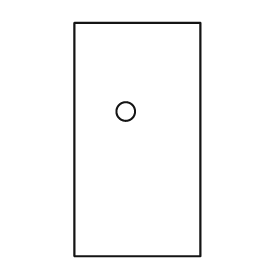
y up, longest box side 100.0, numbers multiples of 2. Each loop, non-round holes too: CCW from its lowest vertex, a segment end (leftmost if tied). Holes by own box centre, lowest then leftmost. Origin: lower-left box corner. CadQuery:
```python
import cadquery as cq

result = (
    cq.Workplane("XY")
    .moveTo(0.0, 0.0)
    .lineTo(54.0, 0.0)
    .lineTo(54.0, 100.0)
    .lineTo(0.0, 100.0)
    .close()
    .moveTo(22.0, 62.0)
    .circle(4.0)
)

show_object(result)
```